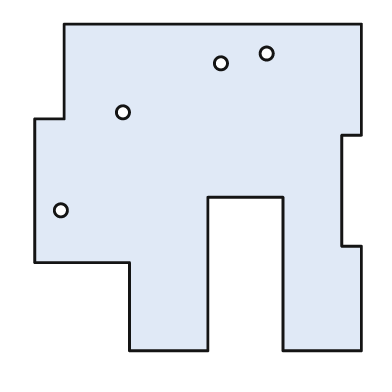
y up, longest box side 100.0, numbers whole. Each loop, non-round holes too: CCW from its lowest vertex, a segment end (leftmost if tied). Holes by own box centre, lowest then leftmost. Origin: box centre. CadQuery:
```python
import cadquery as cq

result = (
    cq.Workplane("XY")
    .moveTo(-21.0, -50.0)
    .lineTo(3.0, -50.0)
    .lineTo(3.0, -3.0)
    .lineTo(26.0, -3.0)
    .lineTo(26.0, -50.0)
    .lineTo(50.0, -50.0)
    .lineTo(50.0, -18.0)
    .lineTo(44.0, -18.0)
    .lineTo(44.0, 16.0)
    .lineTo(50.0, 16.0)
    .lineTo(50.0, 50.0)
    .lineTo(-41.0, 50.0)
    .lineTo(-41.0, 21.0)
    .lineTo(-50.0, 21.0)
    .lineTo(-50.0, -23.0)
    .lineTo(-21.0, -23.0)
    .close()
    .moveTo(-42.0, -7.0)
    .circle(2.0)
    .moveTo(-23.0, 23.0)
    .circle(2.0)
    .moveTo(7.0, 38.0)
    .circle(2.0)
    .moveTo(21.0, 41.0)
    .circle(2.0)
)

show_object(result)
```